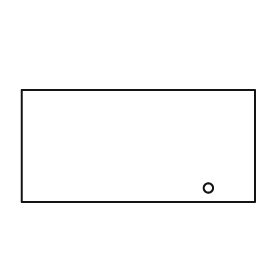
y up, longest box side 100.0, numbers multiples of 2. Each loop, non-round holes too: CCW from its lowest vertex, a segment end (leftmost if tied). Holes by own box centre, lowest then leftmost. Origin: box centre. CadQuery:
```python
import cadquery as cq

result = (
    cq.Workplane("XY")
    .moveTo(-50.0, -24.0)
    .lineTo(50.0, -24.0)
    .lineTo(50.0, 24.0)
    .lineTo(-50.0, 24.0)
    .close()
    .moveTo(30.0, -18.0)
    .circle(2.0)
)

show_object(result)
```